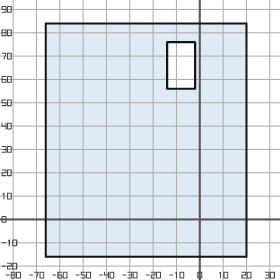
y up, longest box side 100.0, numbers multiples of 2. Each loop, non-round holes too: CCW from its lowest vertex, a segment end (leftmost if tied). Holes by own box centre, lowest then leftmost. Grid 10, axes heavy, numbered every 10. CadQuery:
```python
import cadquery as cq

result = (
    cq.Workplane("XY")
    .moveTo(-66.0, -16.0)
    .lineTo(20.0, -16.0)
    .lineTo(20.0, 84.0)
    .lineTo(-66.0, 84.0)
    .close()
    .moveTo(-14.0, 56.0)
    .lineTo(-2.0, 56.0)
    .lineTo(-2.0, 76.0)
    .lineTo(-14.0, 76.0)
    .close()
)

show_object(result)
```